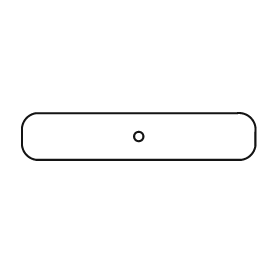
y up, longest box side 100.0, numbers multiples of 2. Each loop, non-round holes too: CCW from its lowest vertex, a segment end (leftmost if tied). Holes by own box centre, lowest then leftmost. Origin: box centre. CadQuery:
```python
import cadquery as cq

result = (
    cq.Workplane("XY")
    .moveTo(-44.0, -10.0)
    .lineTo(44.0, -10.0)
    .threePointArc((48.0, -8.0), (50.0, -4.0))
    .lineTo(50.0, 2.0)
    .threePointArc((48.0, 8.0), (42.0, 10.0))
    .lineTo(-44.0, 10.0)
    .threePointArc((-48.0, 8.0), (-50.0, 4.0))
    .lineTo(-50.0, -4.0)
    .threePointArc((-48.0, -8.0), (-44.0, -10.0))
    .close()
    .moveTo(0.0, 0.0)
    .circle(2.0)
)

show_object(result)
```